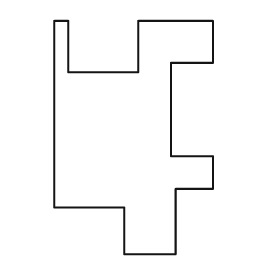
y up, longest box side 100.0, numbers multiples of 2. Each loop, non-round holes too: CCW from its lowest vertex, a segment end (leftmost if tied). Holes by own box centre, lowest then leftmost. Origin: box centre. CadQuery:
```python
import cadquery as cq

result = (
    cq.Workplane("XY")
    .moveTo(-4.0, -50.0)
    .lineTo(18.0, -50.0)
    .lineTo(18.0, -22.0)
    .lineTo(34.0, -22.0)
    .lineTo(34.0, -8.0)
    .lineTo(16.0, -8.0)
    .lineTo(16.0, 32.0)
    .lineTo(34.0, 32.0)
    .lineTo(34.0, 50.0)
    .lineTo(2.0, 50.0)
    .lineTo(2.0, 28.0)
    .lineTo(-28.0, 28.0)
    .lineTo(-28.0, 50.0)
    .lineTo(-34.0, 50.0)
    .lineTo(-34.0, -30.0)
    .lineTo(-4.0, -30.0)
    .close()
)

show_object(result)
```